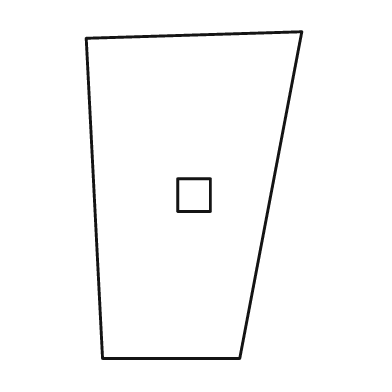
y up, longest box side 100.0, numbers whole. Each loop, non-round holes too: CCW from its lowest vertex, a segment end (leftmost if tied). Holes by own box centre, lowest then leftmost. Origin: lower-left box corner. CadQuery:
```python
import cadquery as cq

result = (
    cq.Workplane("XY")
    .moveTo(5.0, 0.0)
    .lineTo(47.0, 0.0)
    .lineTo(66.0, 100.0)
    .lineTo(0.0, 98.0)
    .close()
    .moveTo(28.0, 45.0)
    .lineTo(38.0, 45.0)
    .lineTo(38.0, 55.0)
    .lineTo(28.0, 55.0)
    .close()
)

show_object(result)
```